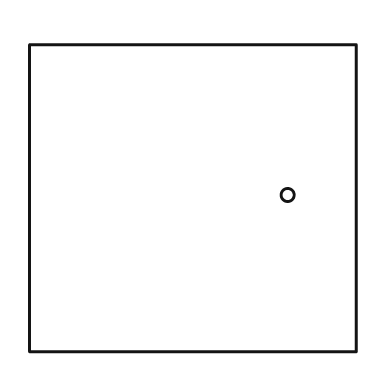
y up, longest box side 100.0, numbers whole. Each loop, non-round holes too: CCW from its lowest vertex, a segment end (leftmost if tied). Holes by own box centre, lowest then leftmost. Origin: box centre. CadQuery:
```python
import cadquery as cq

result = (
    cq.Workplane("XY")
    .moveTo(-50.0, -47.0)
    .lineTo(50.0, -47.0)
    .lineTo(50.0, 47.0)
    .lineTo(-50.0, 47.0)
    .close()
    .moveTo(29.0, 1.0)
    .circle(2.0)
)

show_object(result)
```